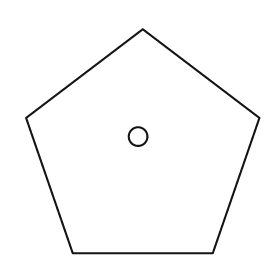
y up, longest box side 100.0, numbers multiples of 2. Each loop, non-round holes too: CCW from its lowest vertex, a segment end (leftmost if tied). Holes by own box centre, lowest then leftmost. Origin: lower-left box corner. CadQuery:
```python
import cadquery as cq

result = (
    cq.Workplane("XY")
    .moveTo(20.0, 0.0)
    .lineTo(80.0, 0.0)
    .lineTo(100.0, 58.0)
    .lineTo(50.0, 96.0)
    .lineTo(0.0, 58.0)
    .close()
    .moveTo(48.0, 50.0)
    .circle(4.0)
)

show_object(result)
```